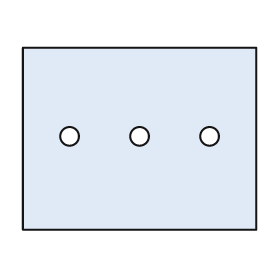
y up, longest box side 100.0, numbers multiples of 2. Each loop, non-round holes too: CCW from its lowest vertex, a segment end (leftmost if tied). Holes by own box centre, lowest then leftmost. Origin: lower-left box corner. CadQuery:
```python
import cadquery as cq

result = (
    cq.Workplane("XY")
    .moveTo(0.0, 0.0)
    .lineTo(100.0, 0.0)
    .lineTo(100.0, 78.0)
    .lineTo(0.0, 78.0)
    .close()
    .moveTo(20.0, 40.0)
    .circle(4.0)
    .moveTo(50.0, 40.0)
    .circle(4.0)
    .moveTo(80.0, 40.0)
    .circle(4.0)
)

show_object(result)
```